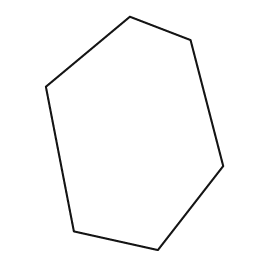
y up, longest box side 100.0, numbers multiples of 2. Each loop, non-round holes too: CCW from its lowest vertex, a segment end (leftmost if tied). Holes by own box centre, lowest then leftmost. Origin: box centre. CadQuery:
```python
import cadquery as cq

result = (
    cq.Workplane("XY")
    .moveTo(10.0, -50.0)
    .lineTo(38.0, -14.0)
    .lineTo(24.0, 40.0)
    .lineTo(-2.0, 50.0)
    .lineTo(-38.0, 20.0)
    .lineTo(-26.0, -42.0)
    .close()
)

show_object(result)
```